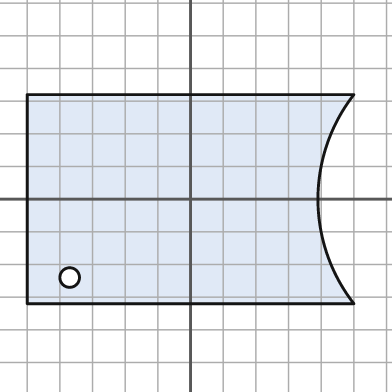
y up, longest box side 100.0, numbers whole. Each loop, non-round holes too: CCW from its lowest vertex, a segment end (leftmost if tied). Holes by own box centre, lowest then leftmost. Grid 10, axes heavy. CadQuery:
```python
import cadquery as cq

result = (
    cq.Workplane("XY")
    .moveTo(-50.0, -32.0)
    .lineTo(50.0, -32.0)
    .threePointArc((39.0, 0.0), (50.0, 32.0))
    .lineTo(-50.0, 32.0)
    .close()
    .moveTo(-37.0, -24.0)
    .circle(3.0)
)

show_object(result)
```